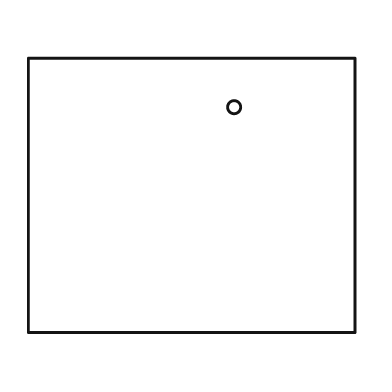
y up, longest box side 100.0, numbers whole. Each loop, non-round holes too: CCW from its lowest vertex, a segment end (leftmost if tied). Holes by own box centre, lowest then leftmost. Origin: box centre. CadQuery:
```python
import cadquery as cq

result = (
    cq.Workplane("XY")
    .moveTo(-50.0, -42.0)
    .lineTo(50.0, -42.0)
    .lineTo(50.0, 42.0)
    .lineTo(-50.0, 42.0)
    .close()
    .moveTo(13.0, 27.0)
    .circle(2.0)
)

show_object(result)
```